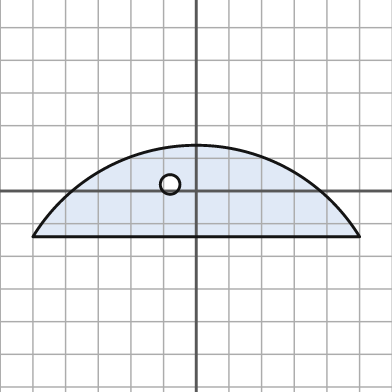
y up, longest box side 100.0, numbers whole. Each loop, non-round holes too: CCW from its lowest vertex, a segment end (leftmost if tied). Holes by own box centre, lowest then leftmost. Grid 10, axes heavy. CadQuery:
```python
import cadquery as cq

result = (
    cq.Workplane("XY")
    .moveTo(-50.0, -14.0)
    .lineTo(50.0, -14.0)
    .threePointArc((0.0, 14.0), (-50.0, -14.0))
    .close()
    .moveTo(-8.0, 2.0)
    .circle(3.0)
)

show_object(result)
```